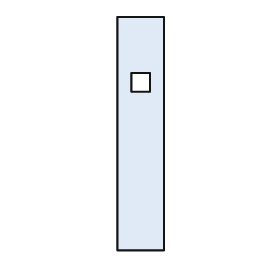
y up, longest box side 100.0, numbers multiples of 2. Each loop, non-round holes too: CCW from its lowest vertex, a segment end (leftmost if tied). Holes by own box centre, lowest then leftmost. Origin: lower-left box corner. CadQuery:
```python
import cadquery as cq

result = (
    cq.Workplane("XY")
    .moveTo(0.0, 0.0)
    .lineTo(20.0, 0.0)
    .lineTo(20.0, 100.0)
    .lineTo(0.0, 100.0)
    .close()
    .moveTo(6.0, 68.0)
    .lineTo(14.0, 68.0)
    .lineTo(14.0, 76.0)
    .lineTo(6.0, 76.0)
    .close()
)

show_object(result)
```